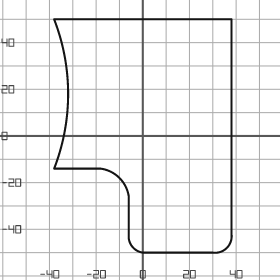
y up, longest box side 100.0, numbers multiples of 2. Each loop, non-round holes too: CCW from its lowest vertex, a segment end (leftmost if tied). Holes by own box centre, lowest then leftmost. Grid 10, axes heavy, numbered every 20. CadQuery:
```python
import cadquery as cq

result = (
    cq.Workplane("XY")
    .moveTo(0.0, -50.0)
    .lineTo(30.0, -50.0)
    .threePointArc((36.0, -48.0), (38.0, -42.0))
    .lineTo(38.0, 50.0)
    .lineTo(-38.0, 50.0)
    .threePointArc((-32.0, 18.0), (-38.0, -14.0))
    .lineTo(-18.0, -14.0)
    .threePointArc((-10.0, -18.0), (-6.0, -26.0))
    .lineTo(-6.0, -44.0)
    .threePointArc((-4.0, -48.0), (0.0, -50.0))
    .close()
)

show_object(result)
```